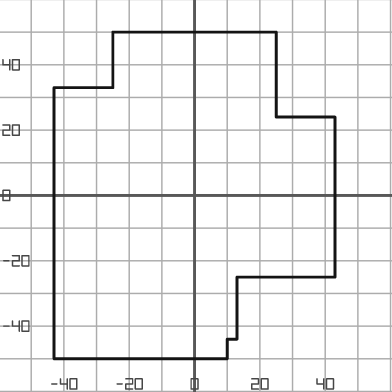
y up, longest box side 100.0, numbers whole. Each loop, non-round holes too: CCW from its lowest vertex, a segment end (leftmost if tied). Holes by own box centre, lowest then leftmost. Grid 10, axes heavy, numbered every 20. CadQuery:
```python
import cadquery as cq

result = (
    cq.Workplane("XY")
    .moveTo(-43.0, -50.0)
    .lineTo(10.0, -50.0)
    .lineTo(10.0, -44.0)
    .lineTo(13.0, -44.0)
    .lineTo(13.0, -25.0)
    .lineTo(43.0, -25.0)
    .lineTo(43.0, 24.0)
    .lineTo(25.0, 24.0)
    .lineTo(25.0, 50.0)
    .lineTo(-25.0, 50.0)
    .lineTo(-25.0, 33.0)
    .lineTo(-43.0, 33.0)
    .close()
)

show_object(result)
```